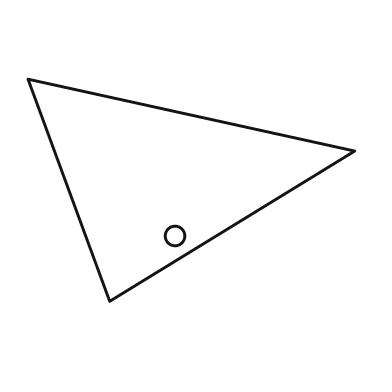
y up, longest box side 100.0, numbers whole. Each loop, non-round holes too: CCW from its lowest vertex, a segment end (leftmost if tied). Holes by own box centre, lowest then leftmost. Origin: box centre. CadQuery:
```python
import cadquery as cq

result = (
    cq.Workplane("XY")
    .moveTo(-25.0, -34.0)
    .lineTo(50.0, 12.0)
    .lineTo(-50.0, 34.0)
    .close()
    .moveTo(-5.0, -14.0)
    .circle(3.0)
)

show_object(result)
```